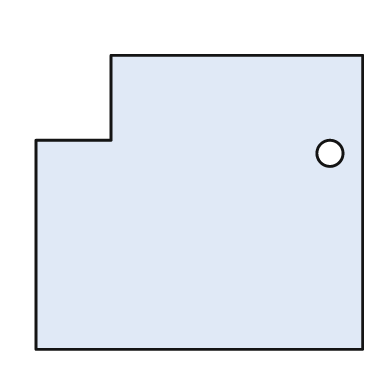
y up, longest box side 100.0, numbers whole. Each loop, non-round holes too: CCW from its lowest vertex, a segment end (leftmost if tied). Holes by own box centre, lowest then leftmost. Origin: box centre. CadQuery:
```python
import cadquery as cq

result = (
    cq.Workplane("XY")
    .moveTo(-50.0, -45.0)
    .lineTo(50.0, -45.0)
    .lineTo(50.0, 45.0)
    .lineTo(-27.0, 45.0)
    .lineTo(-27.0, 19.0)
    .lineTo(-50.0, 19.0)
    .close()
    .moveTo(40.0, 15.0)
    .circle(4.0)
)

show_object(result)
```